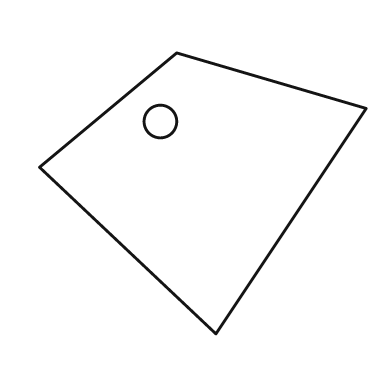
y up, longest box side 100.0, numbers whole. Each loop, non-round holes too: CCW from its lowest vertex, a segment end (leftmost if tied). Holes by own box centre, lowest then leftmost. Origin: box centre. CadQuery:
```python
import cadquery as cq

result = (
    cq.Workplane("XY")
    .moveTo(4.0, -43.0)
    .lineTo(50.0, 26.0)
    .lineTo(-8.0, 43.0)
    .lineTo(-50.0, 8.0)
    .close()
    .moveTo(-13.0, 22.0)
    .circle(5.0)
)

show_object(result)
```